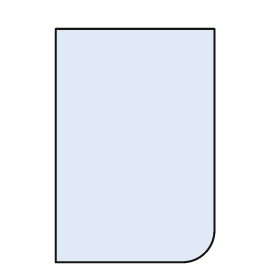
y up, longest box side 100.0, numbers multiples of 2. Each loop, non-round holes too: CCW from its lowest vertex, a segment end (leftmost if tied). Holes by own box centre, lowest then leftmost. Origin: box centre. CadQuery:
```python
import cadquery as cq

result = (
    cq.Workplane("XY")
    .moveTo(-34.0, -50.0)
    .lineTo(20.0, -50.0)
    .threePointArc((30.0, -46.0), (34.0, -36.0))
    .lineTo(34.0, 50.0)
    .lineTo(-34.0, 50.0)
    .close()
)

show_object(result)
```